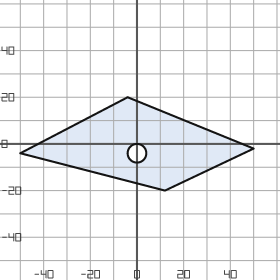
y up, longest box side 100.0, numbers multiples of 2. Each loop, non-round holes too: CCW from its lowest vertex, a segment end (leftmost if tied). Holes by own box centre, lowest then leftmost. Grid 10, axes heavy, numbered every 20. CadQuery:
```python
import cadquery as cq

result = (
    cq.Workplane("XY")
    .moveTo(12.0, -20.0)
    .lineTo(50.0, -2.0)
    .lineTo(-4.0, 20.0)
    .lineTo(-50.0, -4.0)
    .close()
    .moveTo(0.0, -4.0)
    .circle(4.0)
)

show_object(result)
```